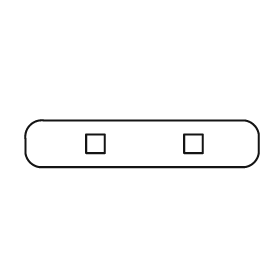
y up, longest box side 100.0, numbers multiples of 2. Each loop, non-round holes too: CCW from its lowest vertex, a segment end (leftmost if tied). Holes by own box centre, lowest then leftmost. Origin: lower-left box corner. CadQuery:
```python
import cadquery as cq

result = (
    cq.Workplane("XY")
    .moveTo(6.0, 0.0)
    .lineTo(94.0, 0.0)
    .threePointArc((98.0, 2.0), (100.0, 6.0))
    .lineTo(100.0, 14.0)
    .threePointArc((98.0, 18.0), (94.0, 20.0))
    .lineTo(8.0, 20.0)
    .threePointArc((2.0, 18.0), (0.0, 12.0))
    .lineTo(0.0, 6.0)
    .threePointArc((2.0, 2.0), (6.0, 0.0))
    .close()
    .moveTo(26.0, 6.0)
    .lineTo(34.0, 6.0)
    .lineTo(34.0, 14.0)
    .lineTo(26.0, 14.0)
    .close()
    .moveTo(68.0, 6.0)
    .lineTo(76.0, 6.0)
    .lineTo(76.0, 14.0)
    .lineTo(68.0, 14.0)
    .close()
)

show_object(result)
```